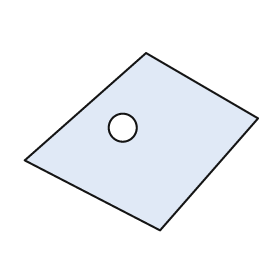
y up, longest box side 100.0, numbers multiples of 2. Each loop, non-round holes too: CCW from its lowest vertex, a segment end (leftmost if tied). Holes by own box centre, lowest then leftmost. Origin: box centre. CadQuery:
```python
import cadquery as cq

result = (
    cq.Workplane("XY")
    .moveTo(8.0, -38.0)
    .lineTo(50.0, 10.0)
    .lineTo(2.0, 38.0)
    .lineTo(-50.0, -8.0)
    .close()
    .moveTo(-8.0, 6.0)
    .circle(6.0)
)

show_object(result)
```